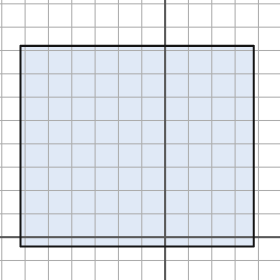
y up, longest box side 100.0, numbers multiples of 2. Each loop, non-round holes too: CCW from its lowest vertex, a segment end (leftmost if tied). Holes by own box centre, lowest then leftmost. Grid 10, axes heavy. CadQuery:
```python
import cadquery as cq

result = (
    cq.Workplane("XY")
    .moveTo(-62.0, -4.0)
    .lineTo(38.0, -4.0)
    .lineTo(38.0, 82.0)
    .lineTo(-62.0, 82.0)
    .close()
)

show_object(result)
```